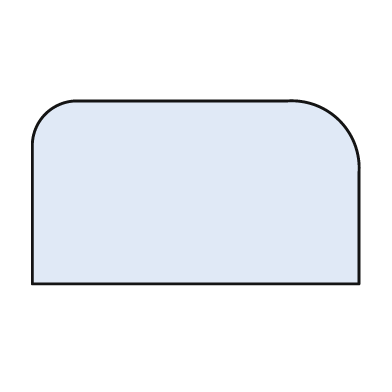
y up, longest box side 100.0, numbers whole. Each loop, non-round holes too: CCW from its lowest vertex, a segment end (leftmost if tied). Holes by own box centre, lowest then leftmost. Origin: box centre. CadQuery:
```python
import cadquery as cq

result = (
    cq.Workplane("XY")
    .moveTo(-50.0, -28.0)
    .lineTo(50.0, -28.0)
    .lineTo(50.0, 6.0)
    .threePointArc((44.0, 22.0), (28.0, 28.0))
    .lineTo(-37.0, 28.0)
    .threePointArc((-46.0, 24.0), (-50.0, 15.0))
    .close()
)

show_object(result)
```